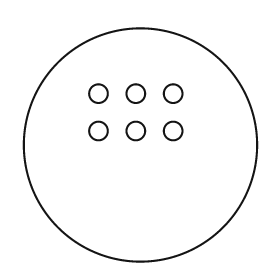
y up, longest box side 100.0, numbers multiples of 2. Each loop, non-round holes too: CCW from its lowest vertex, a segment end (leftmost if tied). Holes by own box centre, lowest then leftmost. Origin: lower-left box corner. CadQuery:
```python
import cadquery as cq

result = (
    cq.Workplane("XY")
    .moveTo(50.0, 50.0)
    .circle(50.0)
    .moveTo(32.0, 56.0)
    .circle(4.0)
    .moveTo(48.0, 56.0)
    .circle(4.0)
    .moveTo(64.0, 56.0)
    .circle(4.0)
    .moveTo(32.0, 72.0)
    .circle(4.0)
    .moveTo(48.0, 72.0)
    .circle(4.0)
    .moveTo(64.0, 72.0)
    .circle(4.0)
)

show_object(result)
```